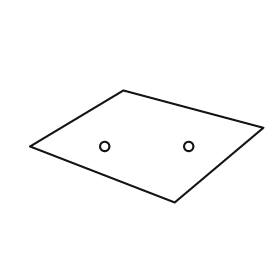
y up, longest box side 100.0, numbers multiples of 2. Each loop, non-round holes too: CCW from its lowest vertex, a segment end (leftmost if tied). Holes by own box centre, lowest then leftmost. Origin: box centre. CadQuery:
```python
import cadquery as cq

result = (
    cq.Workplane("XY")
    .moveTo(12.0, -24.0)
    .lineTo(50.0, 8.0)
    .lineTo(-10.0, 24.0)
    .lineTo(-50.0, 0.0)
    .close()
    .moveTo(-18.0, 0.0)
    .circle(2.0)
    .moveTo(18.0, 0.0)
    .circle(2.0)
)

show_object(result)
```